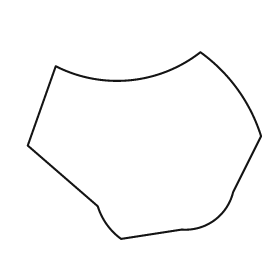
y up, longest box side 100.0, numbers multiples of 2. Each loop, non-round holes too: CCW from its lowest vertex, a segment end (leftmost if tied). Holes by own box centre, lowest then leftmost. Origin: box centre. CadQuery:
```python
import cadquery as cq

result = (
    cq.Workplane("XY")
    .moveTo(-10.0, -40.0)
    .lineTo(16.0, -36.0)
    .threePointArc((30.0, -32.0), (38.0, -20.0))
    .lineTo(50.0, 4.0)
    .threePointArc((40.0, 24.0), (24.0, 40.0))
    .threePointArc((-6.0, 28.0), (-38.0, 34.0))
    .lineTo(-50.0, 0.0)
    .lineTo(-20.0, -26.0)
    .threePointArc((-16.0, -34.0), (-10.0, -40.0))
    .close()
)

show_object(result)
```